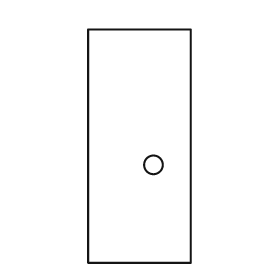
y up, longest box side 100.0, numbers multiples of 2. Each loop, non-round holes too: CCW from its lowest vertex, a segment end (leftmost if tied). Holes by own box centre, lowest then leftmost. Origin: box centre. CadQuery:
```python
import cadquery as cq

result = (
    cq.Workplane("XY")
    .moveTo(-22.0, -50.0)
    .lineTo(22.0, -50.0)
    .lineTo(22.0, 50.0)
    .lineTo(-22.0, 50.0)
    .close()
    .moveTo(6.0, -8.0)
    .circle(4.0)
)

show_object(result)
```